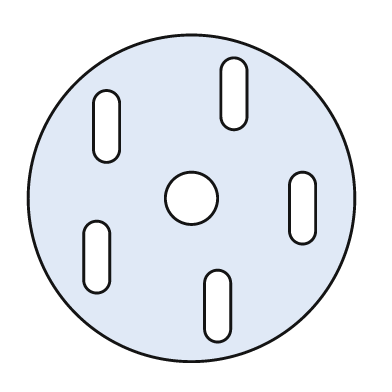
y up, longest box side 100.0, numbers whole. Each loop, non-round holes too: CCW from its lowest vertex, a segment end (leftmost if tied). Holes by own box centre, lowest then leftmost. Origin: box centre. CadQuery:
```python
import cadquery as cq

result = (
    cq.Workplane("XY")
    .moveTo(0.0, 0.0)
    .circle(50.0)
    .moveTo(4.0, -40.0)
    .threePointArc((8.0, -44.0), (12.0, -40.0))
    .lineTo(12.0, -26.0)
    .threePointArc((8.0, -22.0), (4.0, -26.0))
    .close()
    .moveTo(-33.0, -25.0)
    .threePointArc((-29.0, -29.0), (-25.0, -25.0))
    .lineTo(-25.0, -11.0)
    .threePointArc((-29.0, -7.0), (-33.0, -11.0))
    .close()
    .moveTo(30.0, -10.0)
    .threePointArc((34.0, -14.0), (38.0, -10.0))
    .lineTo(38.0, 4.0)
    .threePointArc((34.0, 8.0), (30.0, 4.0))
    .close()
    .moveTo(0.0, 0.0)
    .circle(8.0)
    .moveTo(-30.0, 15.0)
    .threePointArc((-26.0, 11.0), (-22.0, 15.0))
    .lineTo(-22.0, 29.0)
    .threePointArc((-26.0, 33.0), (-30.0, 29.0))
    .close()
    .moveTo(9.0, 25.0)
    .threePointArc((13.0, 21.0), (17.0, 25.0))
    .lineTo(17.0, 39.0)
    .threePointArc((13.0, 43.0), (9.0, 39.0))
    .close()
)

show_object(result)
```